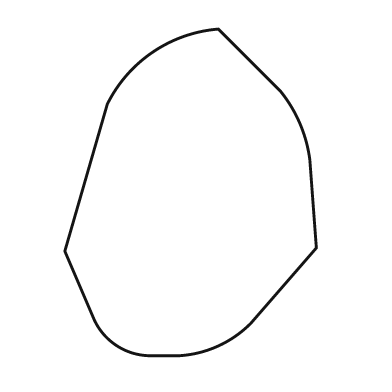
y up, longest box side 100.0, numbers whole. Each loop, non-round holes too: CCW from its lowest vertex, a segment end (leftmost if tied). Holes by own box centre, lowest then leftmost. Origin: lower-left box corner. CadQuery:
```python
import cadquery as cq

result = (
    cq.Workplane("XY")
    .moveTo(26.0, 0.0)
    .lineTo(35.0, 0.0)
    .threePointArc((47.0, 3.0), (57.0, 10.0))
    .lineTo(77.0, 33.0)
    .lineTo(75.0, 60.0)
    .threePointArc((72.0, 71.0), (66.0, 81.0))
    .lineTo(47.0, 100.0)
    .threePointArc((27.0, 93.0), (13.0, 77.0))
    .lineTo(0.0, 32.0)
    .lineTo(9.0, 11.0)
    .threePointArc((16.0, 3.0), (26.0, 0.0))
    .close()
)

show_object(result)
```